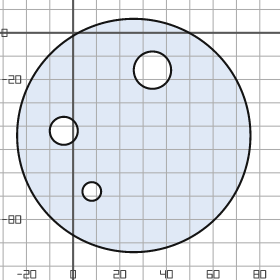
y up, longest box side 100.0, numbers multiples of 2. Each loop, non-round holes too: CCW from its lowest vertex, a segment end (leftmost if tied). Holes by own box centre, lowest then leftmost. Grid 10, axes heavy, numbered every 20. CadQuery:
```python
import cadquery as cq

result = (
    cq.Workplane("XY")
    .moveTo(26.0, -44.0)
    .circle(50.0)
    .moveTo(8.0, -68.0)
    .circle(4.0)
    .moveTo(-4.0, -42.0)
    .circle(6.0)
    .moveTo(34.0, -16.0)
    .circle(8.0)
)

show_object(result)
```